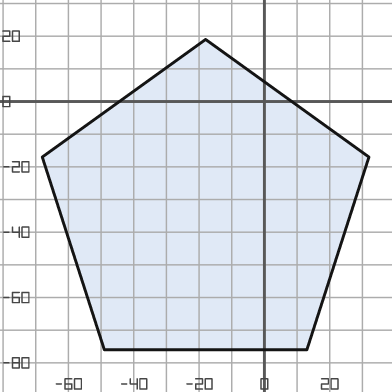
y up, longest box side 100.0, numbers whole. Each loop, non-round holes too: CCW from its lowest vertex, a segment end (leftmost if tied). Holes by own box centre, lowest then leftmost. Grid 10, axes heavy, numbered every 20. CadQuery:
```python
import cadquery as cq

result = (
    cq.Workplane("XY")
    .moveTo(-49.0, -76.0)
    .lineTo(13.0, -76.0)
    .lineTo(32.0, -17.0)
    .lineTo(-18.0, 19.0)
    .lineTo(-68.0, -17.0)
    .close()
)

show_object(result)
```